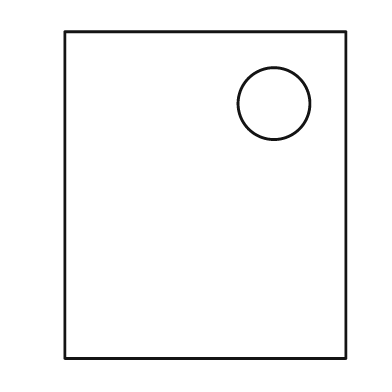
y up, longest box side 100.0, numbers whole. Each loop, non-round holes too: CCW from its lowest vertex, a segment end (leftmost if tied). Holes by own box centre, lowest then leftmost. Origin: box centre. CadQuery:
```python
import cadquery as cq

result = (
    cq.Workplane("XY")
    .moveTo(-43.0, -50.0)
    .lineTo(43.0, -50.0)
    .lineTo(43.0, 50.0)
    .lineTo(-43.0, 50.0)
    .close()
    .moveTo(21.0, 28.0)
    .circle(11.0)
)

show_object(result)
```